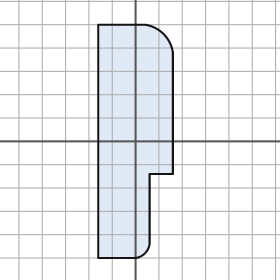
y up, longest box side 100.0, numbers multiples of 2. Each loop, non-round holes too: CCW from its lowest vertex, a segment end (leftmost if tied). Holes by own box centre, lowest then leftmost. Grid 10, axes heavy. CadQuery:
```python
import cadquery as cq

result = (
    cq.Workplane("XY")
    .moveTo(-16.0, -50.0)
    .lineTo(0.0, -50.0)
    .threePointArc((4.0, -48.0), (6.0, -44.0))
    .lineTo(6.0, -14.0)
    .lineTo(16.0, -14.0)
    .lineTo(16.0, 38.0)
    .threePointArc((12.0, 46.0), (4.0, 50.0))
    .lineTo(-16.0, 50.0)
    .close()
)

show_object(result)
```